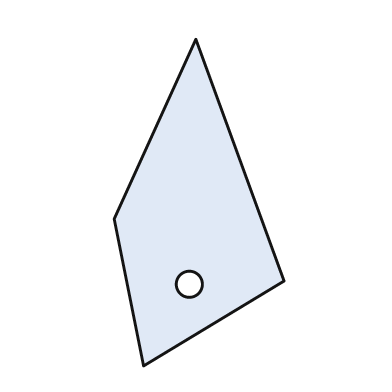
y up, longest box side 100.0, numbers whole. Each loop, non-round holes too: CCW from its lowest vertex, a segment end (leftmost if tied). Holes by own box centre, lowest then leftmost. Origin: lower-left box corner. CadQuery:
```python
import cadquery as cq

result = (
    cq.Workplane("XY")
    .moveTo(9.0, 0.0)
    .lineTo(52.0, 26.0)
    .lineTo(25.0, 100.0)
    .lineTo(0.0, 45.0)
    .close()
    .moveTo(23.0, 25.0)
    .circle(4.0)
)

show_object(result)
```